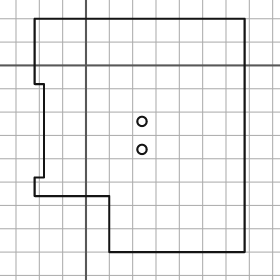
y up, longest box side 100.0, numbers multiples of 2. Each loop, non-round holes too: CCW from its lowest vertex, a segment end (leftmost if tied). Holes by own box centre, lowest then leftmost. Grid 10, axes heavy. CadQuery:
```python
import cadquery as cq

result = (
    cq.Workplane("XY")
    .moveTo(10.0, -80.0)
    .lineTo(68.0, -80.0)
    .lineTo(68.0, 20.0)
    .lineTo(-22.0, 20.0)
    .lineTo(-22.0, -8.0)
    .lineTo(-18.0, -8.0)
    .lineTo(-18.0, -48.0)
    .lineTo(-22.0, -48.0)
    .lineTo(-22.0, -56.0)
    .lineTo(10.0, -56.0)
    .close()
    .moveTo(24.0, -36.0)
    .circle(2.0)
    .moveTo(24.0, -24.0)
    .circle(2.0)
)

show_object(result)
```